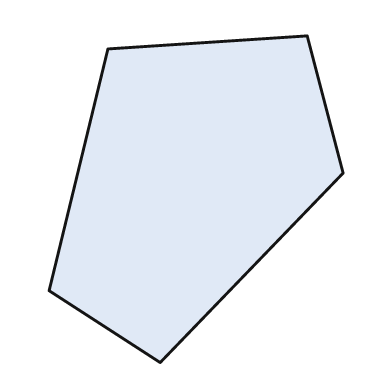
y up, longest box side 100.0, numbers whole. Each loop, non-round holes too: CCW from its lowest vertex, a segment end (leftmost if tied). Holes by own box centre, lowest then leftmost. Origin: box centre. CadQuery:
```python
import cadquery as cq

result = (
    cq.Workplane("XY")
    .moveTo(-11.0, -50.0)
    .lineTo(45.0, 8.0)
    .lineTo(34.0, 50.0)
    .lineTo(-27.0, 46.0)
    .lineTo(-45.0, -28.0)
    .close()
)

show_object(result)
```